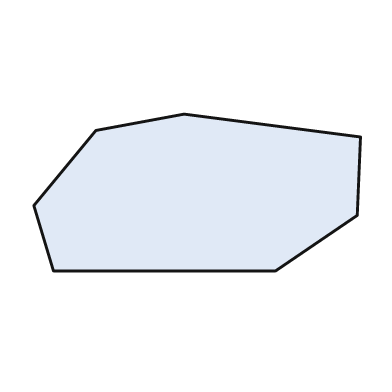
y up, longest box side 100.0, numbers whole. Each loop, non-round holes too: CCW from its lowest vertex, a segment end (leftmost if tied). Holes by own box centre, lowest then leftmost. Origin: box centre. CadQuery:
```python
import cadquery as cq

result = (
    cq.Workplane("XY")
    .moveTo(-44.0, -24.0)
    .lineTo(24.0, -24.0)
    .lineTo(49.0, -7.0)
    .lineTo(50.0, 17.0)
    .lineTo(-4.0, 24.0)
    .lineTo(-31.0, 19.0)
    .lineTo(-50.0, -4.0)
    .close()
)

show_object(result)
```